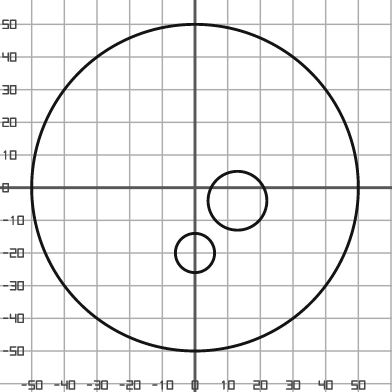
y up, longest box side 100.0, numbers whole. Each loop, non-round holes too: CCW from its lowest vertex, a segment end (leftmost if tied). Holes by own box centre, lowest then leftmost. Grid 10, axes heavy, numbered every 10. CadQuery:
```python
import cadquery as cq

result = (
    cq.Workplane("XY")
    .moveTo(0.0, 0.0)
    .circle(50.0)
    .moveTo(0.0, -20.0)
    .circle(6.0)
    .moveTo(13.0, -4.0)
    .circle(9.0)
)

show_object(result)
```